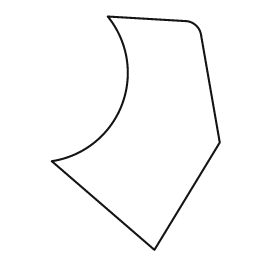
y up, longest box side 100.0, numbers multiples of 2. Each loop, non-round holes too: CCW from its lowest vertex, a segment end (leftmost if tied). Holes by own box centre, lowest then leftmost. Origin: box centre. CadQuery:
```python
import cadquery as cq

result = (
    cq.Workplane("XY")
    .moveTo(8.0, -50.0)
    .lineTo(36.0, -4.0)
    .lineTo(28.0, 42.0)
    .threePointArc((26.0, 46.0), (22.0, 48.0))
    .lineTo(-12.0, 50.0)
    .threePointArc((-6.0, 12.0), (-36.0, -12.0))
    .close()
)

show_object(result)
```